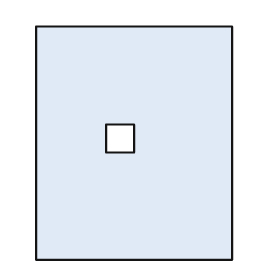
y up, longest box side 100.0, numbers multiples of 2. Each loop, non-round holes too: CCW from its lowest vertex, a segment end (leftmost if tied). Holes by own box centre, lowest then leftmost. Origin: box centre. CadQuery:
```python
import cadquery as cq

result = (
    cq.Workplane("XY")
    .moveTo(-42.0, -50.0)
    .lineTo(42.0, -50.0)
    .lineTo(42.0, 50.0)
    .lineTo(-42.0, 50.0)
    .close()
    .moveTo(-12.0, -4.0)
    .lineTo(0.0, -4.0)
    .lineTo(0.0, 8.0)
    .lineTo(-12.0, 8.0)
    .close()
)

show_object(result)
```